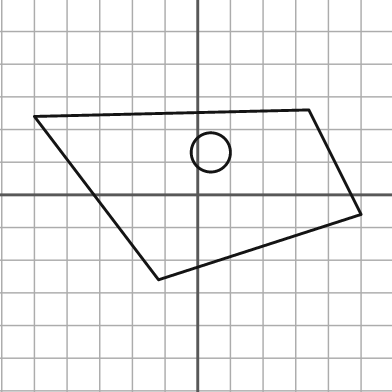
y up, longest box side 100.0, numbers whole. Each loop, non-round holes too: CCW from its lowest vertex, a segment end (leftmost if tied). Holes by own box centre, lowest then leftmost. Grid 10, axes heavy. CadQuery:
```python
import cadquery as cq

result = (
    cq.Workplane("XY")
    .moveTo(-12.0, -26.0)
    .lineTo(50.0, -6.0)
    .lineTo(34.0, 26.0)
    .lineTo(-50.0, 24.0)
    .close()
    .moveTo(4.0, 13.0)
    .circle(6.0)
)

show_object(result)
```